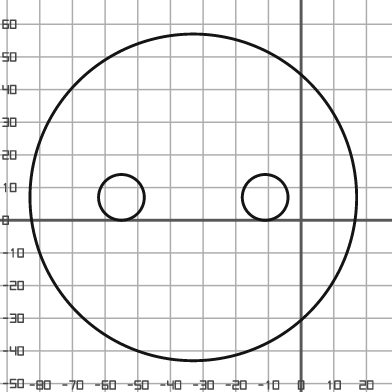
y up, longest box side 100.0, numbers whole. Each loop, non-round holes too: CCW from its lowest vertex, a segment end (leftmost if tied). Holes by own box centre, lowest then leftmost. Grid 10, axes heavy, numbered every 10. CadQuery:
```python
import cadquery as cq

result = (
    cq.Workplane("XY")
    .moveTo(-33.0, 7.0)
    .circle(50.0)
    .moveTo(-55.0, 7.0)
    .circle(7.0)
    .moveTo(-11.0, 7.0)
    .circle(7.0)
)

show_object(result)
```